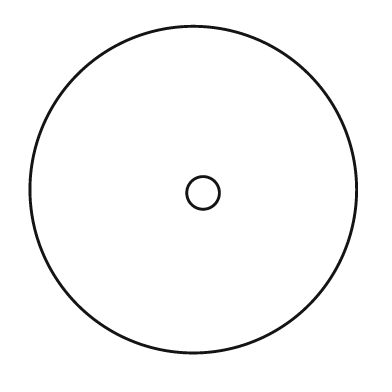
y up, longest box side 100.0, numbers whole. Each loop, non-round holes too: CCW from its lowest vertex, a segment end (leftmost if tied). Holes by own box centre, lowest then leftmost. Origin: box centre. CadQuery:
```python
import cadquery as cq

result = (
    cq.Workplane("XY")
    .moveTo(0.0, 0.0)
    .circle(50.0)
    .moveTo(3.0, -1.0)
    .circle(5.0)
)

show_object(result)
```